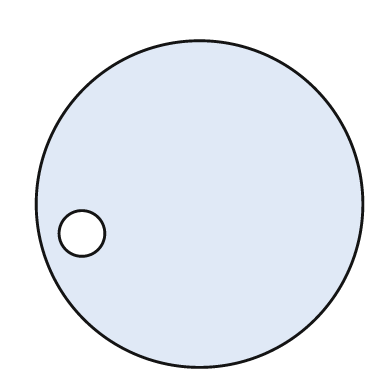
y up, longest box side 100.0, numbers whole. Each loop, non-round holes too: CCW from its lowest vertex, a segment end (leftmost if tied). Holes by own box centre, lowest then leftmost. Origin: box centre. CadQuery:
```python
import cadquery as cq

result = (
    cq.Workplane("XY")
    .moveTo(0.0, 0.0)
    .circle(50.0)
    .moveTo(-36.0, -9.0)
    .circle(7.0)
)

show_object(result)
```